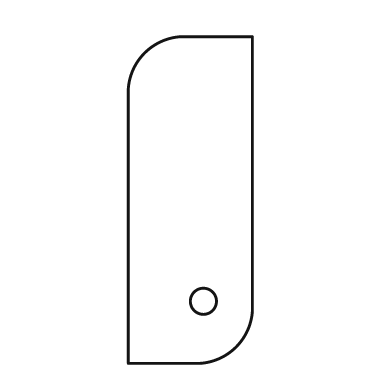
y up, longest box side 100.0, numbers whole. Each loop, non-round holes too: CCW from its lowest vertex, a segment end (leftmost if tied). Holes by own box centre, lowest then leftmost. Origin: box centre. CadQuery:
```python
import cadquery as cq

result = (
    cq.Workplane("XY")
    .moveTo(-19.0, -50.0)
    .lineTo(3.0, -50.0)
    .threePointArc((14.0, -45.0), (19.0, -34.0))
    .lineTo(19.0, 50.0)
    .lineTo(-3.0, 50.0)
    .threePointArc((-14.0, 45.0), (-19.0, 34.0))
    .close()
    .moveTo(4.0, -31.0)
    .circle(4.0)
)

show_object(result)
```